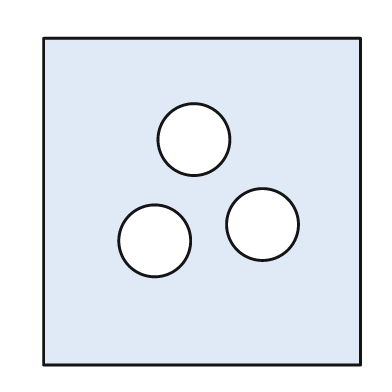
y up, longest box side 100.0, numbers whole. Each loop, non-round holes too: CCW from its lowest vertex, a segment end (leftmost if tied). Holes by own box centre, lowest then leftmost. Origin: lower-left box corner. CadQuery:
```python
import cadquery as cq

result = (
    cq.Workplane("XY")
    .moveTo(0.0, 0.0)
    .lineTo(97.0, 0.0)
    .lineTo(97.0, 100.0)
    .lineTo(0.0, 100.0)
    .close()
    .moveTo(34.0, 38.0)
    .circle(11.0)
    .moveTo(67.0, 43.0)
    .circle(11.0)
    .moveTo(46.0, 69.0)
    .circle(11.0)
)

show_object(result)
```